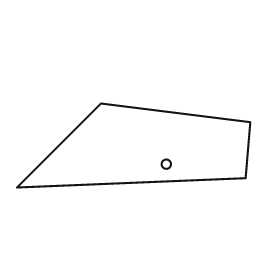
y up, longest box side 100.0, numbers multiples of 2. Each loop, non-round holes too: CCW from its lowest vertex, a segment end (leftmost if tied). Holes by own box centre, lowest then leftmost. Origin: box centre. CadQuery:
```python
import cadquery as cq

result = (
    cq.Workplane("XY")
    .moveTo(-50.0, -18.0)
    .lineTo(48.0, -14.0)
    .lineTo(50.0, 10.0)
    .lineTo(-14.0, 18.0)
    .close()
    .moveTo(14.0, -8.0)
    .circle(2.0)
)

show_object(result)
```